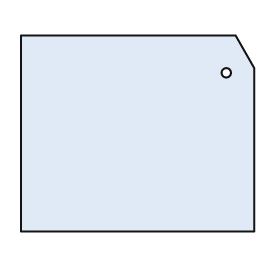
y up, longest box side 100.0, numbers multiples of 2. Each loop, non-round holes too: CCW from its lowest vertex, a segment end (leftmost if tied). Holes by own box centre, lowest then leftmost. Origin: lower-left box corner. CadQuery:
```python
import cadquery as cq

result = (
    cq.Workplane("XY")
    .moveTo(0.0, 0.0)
    .lineTo(100.0, 0.0)
    .lineTo(100.0, 70.0)
    .lineTo(92.0, 84.0)
    .lineTo(0.0, 84.0)
    .close()
    .moveTo(88.0, 68.0)
    .circle(2.0)
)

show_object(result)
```